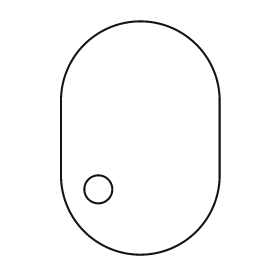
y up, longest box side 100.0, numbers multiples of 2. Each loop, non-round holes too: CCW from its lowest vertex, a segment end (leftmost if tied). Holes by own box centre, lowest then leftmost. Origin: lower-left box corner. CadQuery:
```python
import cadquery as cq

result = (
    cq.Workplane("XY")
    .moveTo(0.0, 34.0)
    .threePointArc((34.0, 0.0), (68.0, 34.0))
    .lineTo(68.0, 66.0)
    .threePointArc((34.0, 100.0), (0.0, 66.0))
    .close()
    .moveTo(16.0, 28.0)
    .circle(6.0)
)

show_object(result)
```